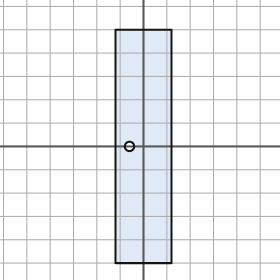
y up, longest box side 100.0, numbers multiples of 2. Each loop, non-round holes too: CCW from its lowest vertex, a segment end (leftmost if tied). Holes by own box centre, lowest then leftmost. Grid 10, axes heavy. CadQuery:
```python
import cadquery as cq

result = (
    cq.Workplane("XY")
    .moveTo(-12.0, -50.0)
    .lineTo(12.0, -50.0)
    .lineTo(12.0, 50.0)
    .lineTo(-12.0, 50.0)
    .close()
    .moveTo(-6.0, 0.0)
    .circle(2.0)
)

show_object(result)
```